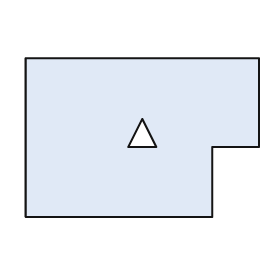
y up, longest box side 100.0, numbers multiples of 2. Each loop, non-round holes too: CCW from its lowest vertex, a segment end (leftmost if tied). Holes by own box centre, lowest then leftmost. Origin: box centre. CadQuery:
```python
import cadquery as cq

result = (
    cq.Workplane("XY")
    .moveTo(-50.0, -34.0)
    .lineTo(30.0, -34.0)
    .lineTo(30.0, -4.0)
    .lineTo(50.0, -4.0)
    .lineTo(50.0, 34.0)
    .lineTo(-50.0, 34.0)
    .close()
    .moveTo(-6.0, -4.0)
    .lineTo(6.0, -4.0)
    .lineTo(0.0, 8.0)
    .close()
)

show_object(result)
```